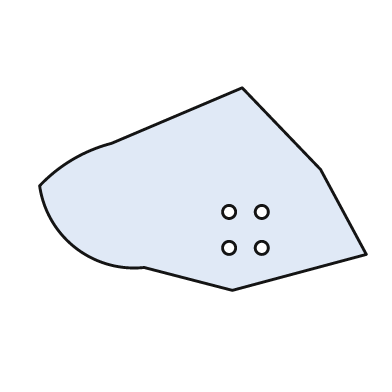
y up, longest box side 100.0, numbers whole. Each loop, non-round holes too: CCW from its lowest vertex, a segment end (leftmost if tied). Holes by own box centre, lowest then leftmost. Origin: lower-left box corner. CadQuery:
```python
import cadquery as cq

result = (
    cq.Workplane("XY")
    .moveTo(59.0, 0.0)
    .lineTo(100.0, 11.0)
    .lineTo(86.0, 37.0)
    .lineTo(62.0, 62.0)
    .lineTo(22.0, 45.0)
    .threePointArc((10.0, 40.0), (0.0, 32.0))
    .threePointArc((11.0, 13.0), (32.0, 7.0))
    .close()
    .moveTo(58.0, 13.0)
    .circle(2.0)
    .moveTo(68.0, 13.0)
    .circle(2.0)
    .moveTo(58.0, 24.0)
    .circle(2.0)
    .moveTo(68.0, 24.0)
    .circle(2.0)
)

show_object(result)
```